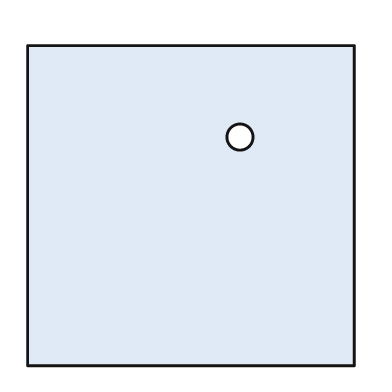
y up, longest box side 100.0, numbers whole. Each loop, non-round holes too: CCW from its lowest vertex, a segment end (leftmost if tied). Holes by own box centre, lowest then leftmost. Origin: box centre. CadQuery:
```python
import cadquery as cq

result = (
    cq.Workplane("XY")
    .moveTo(-50.0, -49.0)
    .lineTo(50.0, -49.0)
    .lineTo(50.0, 49.0)
    .lineTo(-50.0, 49.0)
    .close()
    .moveTo(15.0, 21.0)
    .circle(4.0)
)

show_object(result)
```